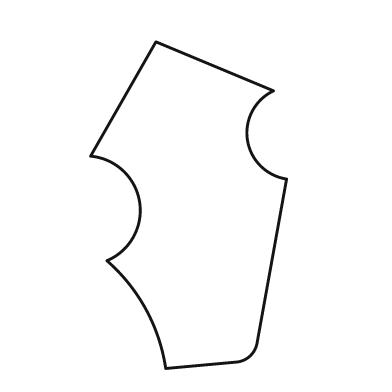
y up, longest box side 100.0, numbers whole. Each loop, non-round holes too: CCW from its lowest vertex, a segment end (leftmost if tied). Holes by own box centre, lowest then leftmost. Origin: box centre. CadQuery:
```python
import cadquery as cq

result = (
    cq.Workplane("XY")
    .moveTo(-7.0, -50.0)
    .lineTo(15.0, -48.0)
    .threePointArc((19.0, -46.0), (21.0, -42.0))
    .lineTo(30.0, 8.0)
    .threePointArc((18.0, 20.0), (26.0, 35.0))
    .lineTo(-10.0, 50.0)
    .lineTo(-30.0, 15.0)
    .threePointArc((-15.0, 1.0), (-25.0, -17.0))
    .threePointArc((-13.0, -32.0), (-7.0, -50.0))
    .close()
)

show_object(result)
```